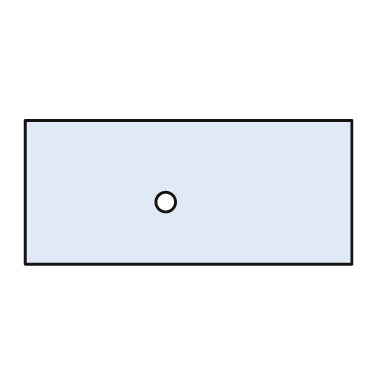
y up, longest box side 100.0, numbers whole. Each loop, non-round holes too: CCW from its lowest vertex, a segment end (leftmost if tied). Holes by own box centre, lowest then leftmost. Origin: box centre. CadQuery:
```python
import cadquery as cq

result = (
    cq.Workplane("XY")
    .moveTo(-50.0, -22.0)
    .lineTo(50.0, -22.0)
    .lineTo(50.0, 22.0)
    .lineTo(-50.0, 22.0)
    .close()
    .moveTo(-7.0, -3.0)
    .circle(3.0)
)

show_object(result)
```